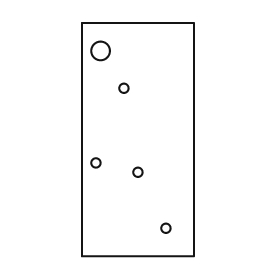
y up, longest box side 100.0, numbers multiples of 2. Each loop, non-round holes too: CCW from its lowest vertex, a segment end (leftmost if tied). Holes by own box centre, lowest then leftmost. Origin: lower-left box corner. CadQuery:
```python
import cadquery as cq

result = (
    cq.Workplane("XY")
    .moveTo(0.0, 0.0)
    .lineTo(48.0, 0.0)
    .lineTo(48.0, 100.0)
    .lineTo(0.0, 100.0)
    .close()
    .moveTo(36.0, 12.0)
    .circle(2.0)
    .moveTo(24.0, 36.0)
    .circle(2.0)
    .moveTo(6.0, 40.0)
    .circle(2.0)
    .moveTo(18.0, 72.0)
    .circle(2.0)
    .moveTo(8.0, 88.0)
    .circle(4.0)
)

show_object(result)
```